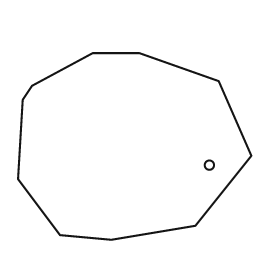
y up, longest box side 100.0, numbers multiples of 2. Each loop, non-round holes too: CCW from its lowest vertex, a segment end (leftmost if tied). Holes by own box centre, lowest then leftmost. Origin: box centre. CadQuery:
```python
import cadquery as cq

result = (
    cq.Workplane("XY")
    .moveTo(-10.0, -40.0)
    .lineTo(26.0, -34.0)
    .lineTo(50.0, -4.0)
    .lineTo(36.0, 28.0)
    .lineTo(2.0, 40.0)
    .lineTo(-18.0, 40.0)
    .lineTo(-44.0, 26.0)
    .lineTo(-48.0, 20.0)
    .lineTo(-50.0, -14.0)
    .lineTo(-32.0, -38.0)
    .close()
    .moveTo(32.0, -8.0)
    .circle(2.0)
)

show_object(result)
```